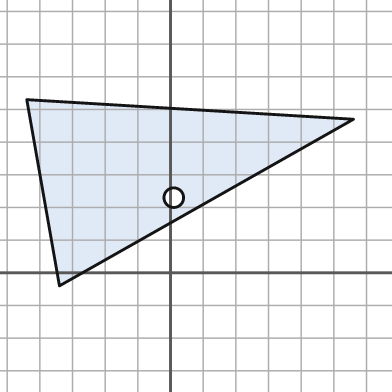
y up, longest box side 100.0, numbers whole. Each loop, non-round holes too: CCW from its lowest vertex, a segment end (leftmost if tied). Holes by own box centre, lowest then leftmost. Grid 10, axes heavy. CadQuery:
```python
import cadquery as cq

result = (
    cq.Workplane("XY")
    .moveTo(-34.0, -4.0)
    .lineTo(56.0, 47.0)
    .lineTo(-44.0, 53.0)
    .close()
    .moveTo(1.0, 23.0)
    .circle(3.0)
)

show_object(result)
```